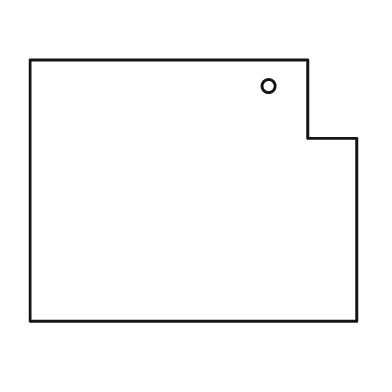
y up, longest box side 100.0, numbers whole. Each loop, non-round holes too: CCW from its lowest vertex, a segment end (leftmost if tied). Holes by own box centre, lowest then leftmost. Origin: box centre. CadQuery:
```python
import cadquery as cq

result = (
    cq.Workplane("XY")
    .moveTo(-50.0, -40.0)
    .lineTo(50.0, -40.0)
    .lineTo(50.0, 16.0)
    .lineTo(35.0, 16.0)
    .lineTo(35.0, 40.0)
    .lineTo(-50.0, 40.0)
    .close()
    .moveTo(23.0, 32.0)
    .circle(2.0)
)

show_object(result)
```